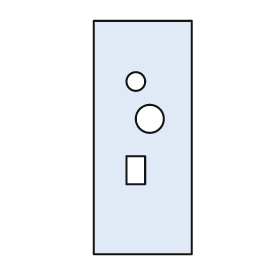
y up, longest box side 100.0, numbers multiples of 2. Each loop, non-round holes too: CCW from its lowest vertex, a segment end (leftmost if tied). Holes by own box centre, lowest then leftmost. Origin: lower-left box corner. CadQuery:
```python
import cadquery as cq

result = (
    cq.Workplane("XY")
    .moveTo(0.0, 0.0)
    .lineTo(42.0, 0.0)
    .lineTo(42.0, 100.0)
    .lineTo(0.0, 100.0)
    .close()
    .moveTo(14.0, 30.0)
    .lineTo(22.0, 30.0)
    .lineTo(22.0, 42.0)
    .lineTo(14.0, 42.0)
    .close()
    .moveTo(24.0, 58.0)
    .circle(6.0)
    .moveTo(18.0, 74.0)
    .circle(4.0)
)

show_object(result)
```